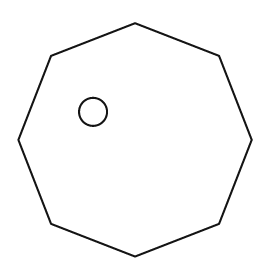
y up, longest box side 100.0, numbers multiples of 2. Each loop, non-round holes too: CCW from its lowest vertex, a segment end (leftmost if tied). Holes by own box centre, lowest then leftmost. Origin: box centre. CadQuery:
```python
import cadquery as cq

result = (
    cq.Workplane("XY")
    .moveTo(0.0, -50.0)
    .lineTo(36.0, -36.0)
    .lineTo(50.0, 0.0)
    .lineTo(36.0, 36.0)
    .lineTo(0.0, 50.0)
    .lineTo(-36.0, 36.0)
    .lineTo(-50.0, 0.0)
    .lineTo(-36.0, -36.0)
    .close()
    .moveTo(-18.0, 12.0)
    .circle(6.0)
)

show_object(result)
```